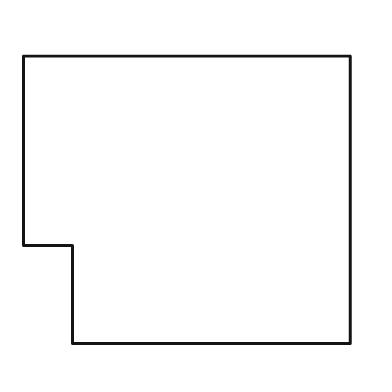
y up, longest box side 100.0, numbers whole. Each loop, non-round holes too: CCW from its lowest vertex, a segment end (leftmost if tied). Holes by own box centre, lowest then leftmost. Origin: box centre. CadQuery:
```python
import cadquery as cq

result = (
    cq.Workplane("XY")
    .moveTo(-35.0, -44.0)
    .lineTo(50.0, -44.0)
    .lineTo(50.0, 44.0)
    .lineTo(-50.0, 44.0)
    .lineTo(-50.0, -14.0)
    .lineTo(-35.0, -14.0)
    .close()
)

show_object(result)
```